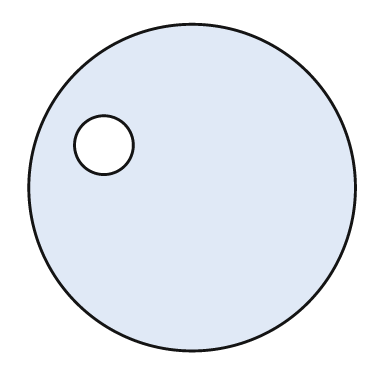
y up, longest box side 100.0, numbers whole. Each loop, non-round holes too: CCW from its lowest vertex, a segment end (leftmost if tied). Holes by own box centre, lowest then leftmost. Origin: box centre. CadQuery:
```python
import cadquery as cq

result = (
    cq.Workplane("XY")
    .moveTo(0.0, 0.0)
    .circle(50.0)
    .moveTo(-27.0, 13.0)
    .circle(9.0)
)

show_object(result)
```